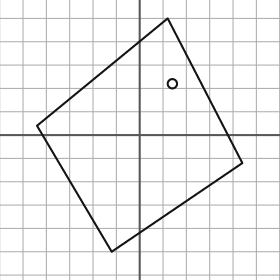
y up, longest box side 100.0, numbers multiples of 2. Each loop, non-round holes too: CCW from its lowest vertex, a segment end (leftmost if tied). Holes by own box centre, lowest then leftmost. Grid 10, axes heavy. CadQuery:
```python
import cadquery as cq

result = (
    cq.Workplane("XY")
    .moveTo(-12.0, -50.0)
    .lineTo(44.0, -12.0)
    .lineTo(12.0, 50.0)
    .lineTo(-44.0, 4.0)
    .close()
    .moveTo(14.0, 22.0)
    .circle(2.0)
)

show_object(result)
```